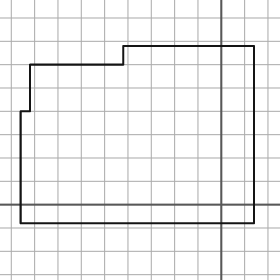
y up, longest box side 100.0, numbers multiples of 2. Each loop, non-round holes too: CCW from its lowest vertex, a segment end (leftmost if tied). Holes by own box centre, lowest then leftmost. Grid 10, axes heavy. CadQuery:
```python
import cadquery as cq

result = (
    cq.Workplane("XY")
    .moveTo(-86.0, -8.0)
    .lineTo(14.0, -8.0)
    .lineTo(14.0, 68.0)
    .lineTo(-42.0, 68.0)
    .lineTo(-42.0, 60.0)
    .lineTo(-82.0, 60.0)
    .lineTo(-82.0, 40.0)
    .lineTo(-86.0, 40.0)
    .close()
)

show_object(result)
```